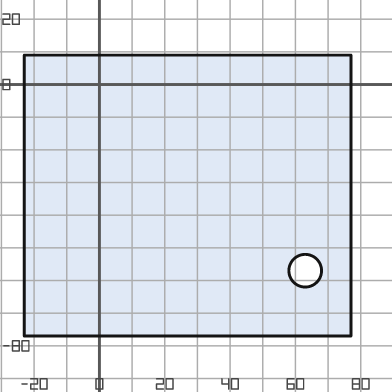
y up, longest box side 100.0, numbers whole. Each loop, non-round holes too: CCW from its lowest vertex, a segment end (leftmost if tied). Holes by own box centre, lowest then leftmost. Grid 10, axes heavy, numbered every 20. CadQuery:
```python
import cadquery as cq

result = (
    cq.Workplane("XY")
    .moveTo(-23.0, -77.0)
    .lineTo(77.0, -77.0)
    .lineTo(77.0, 9.0)
    .lineTo(-23.0, 9.0)
    .close()
    .moveTo(63.0, -57.0)
    .circle(5.0)
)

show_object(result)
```